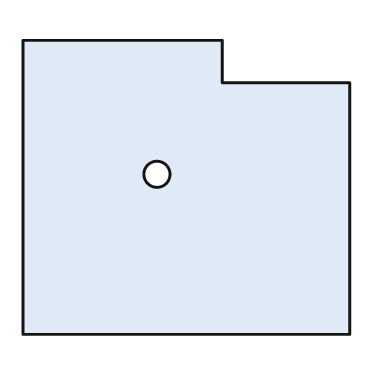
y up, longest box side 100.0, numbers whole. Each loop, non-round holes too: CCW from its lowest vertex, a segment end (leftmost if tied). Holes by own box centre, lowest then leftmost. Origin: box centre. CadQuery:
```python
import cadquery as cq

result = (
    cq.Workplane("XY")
    .moveTo(-50.0, -45.0)
    .lineTo(50.0, -45.0)
    .lineTo(50.0, 32.0)
    .lineTo(11.0, 32.0)
    .lineTo(11.0, 45.0)
    .lineTo(-50.0, 45.0)
    .close()
    .moveTo(-9.0, 4.0)
    .circle(4.0)
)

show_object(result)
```